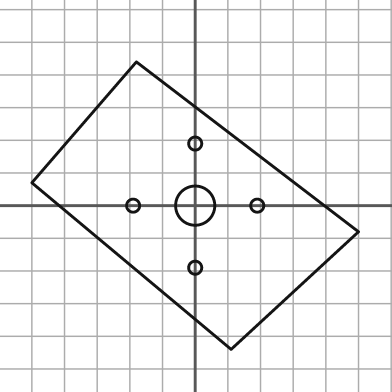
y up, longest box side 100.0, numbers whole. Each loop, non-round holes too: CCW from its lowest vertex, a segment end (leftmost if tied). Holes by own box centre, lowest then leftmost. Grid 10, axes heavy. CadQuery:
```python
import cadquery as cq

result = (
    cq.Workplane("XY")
    .moveTo(11.0, -44.0)
    .lineTo(50.0, -8.0)
    .lineTo(-18.0, 44.0)
    .lineTo(-50.0, 7.0)
    .close()
    .moveTo(0.0, -19.0)
    .circle(2.0)
    .moveTo(-19.0, 0.0)
    .circle(2.0)
    .moveTo(0.0, 0.0)
    .circle(6.0)
    .moveTo(19.0, 0.0)
    .circle(2.0)
    .moveTo(0.0, 19.0)
    .circle(2.0)
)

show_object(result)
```